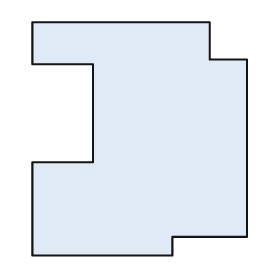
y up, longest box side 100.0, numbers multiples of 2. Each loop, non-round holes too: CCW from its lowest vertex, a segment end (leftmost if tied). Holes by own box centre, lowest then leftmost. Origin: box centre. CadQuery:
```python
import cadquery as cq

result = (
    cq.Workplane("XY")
    .moveTo(-46.0, -50.0)
    .lineTo(14.0, -50.0)
    .lineTo(14.0, -42.0)
    .lineTo(46.0, -42.0)
    .lineTo(46.0, 34.0)
    .lineTo(30.0, 34.0)
    .lineTo(30.0, 50.0)
    .lineTo(-46.0, 50.0)
    .lineTo(-46.0, 32.0)
    .lineTo(-20.0, 32.0)
    .lineTo(-20.0, -10.0)
    .lineTo(-46.0, -10.0)
    .close()
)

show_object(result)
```